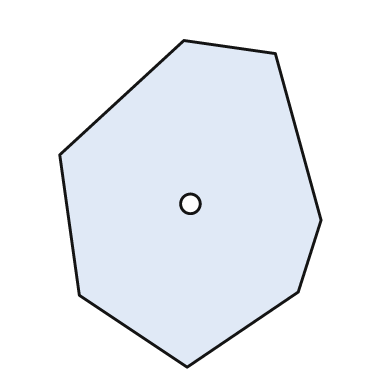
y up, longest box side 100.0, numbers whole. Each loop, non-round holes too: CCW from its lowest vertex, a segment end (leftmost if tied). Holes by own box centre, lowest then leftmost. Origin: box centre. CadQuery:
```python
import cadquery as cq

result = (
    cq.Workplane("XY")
    .moveTo(-1.0, -50.0)
    .lineTo(33.0, -27.0)
    .lineTo(40.0, -5.0)
    .lineTo(26.0, 46.0)
    .lineTo(-2.0, 50.0)
    .lineTo(-40.0, 15.0)
    .lineTo(-34.0, -28.0)
    .close()
    .moveTo(0.0, 0.0)
    .circle(3.0)
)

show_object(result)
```